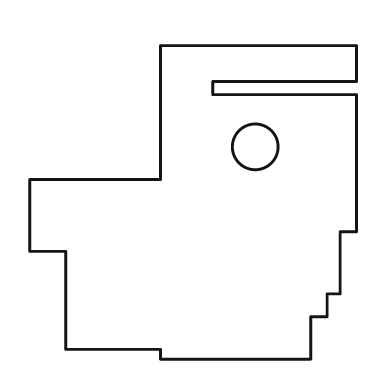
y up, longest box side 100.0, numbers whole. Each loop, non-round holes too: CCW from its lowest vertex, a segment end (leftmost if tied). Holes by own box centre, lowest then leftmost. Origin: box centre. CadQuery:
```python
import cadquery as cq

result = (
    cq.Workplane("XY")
    .moveTo(-10.0, -48.0)
    .lineTo(36.0, -48.0)
    .lineTo(36.0, -35.0)
    .lineTo(41.0, -35.0)
    .lineTo(41.0, -28.0)
    .lineTo(45.0, -28.0)
    .lineTo(45.0, -9.0)
    .lineTo(50.0, -9.0)
    .lineTo(50.0, 33.0)
    .lineTo(6.0, 33.0)
    .lineTo(6.0, 37.0)
    .lineTo(50.0, 37.0)
    .lineTo(50.0, 48.0)
    .lineTo(-10.0, 48.0)
    .lineTo(-10.0, 7.0)
    .lineTo(-50.0, 7.0)
    .lineTo(-50.0, -15.0)
    .lineTo(-39.0, -15.0)
    .lineTo(-39.0, -45.0)
    .lineTo(-10.0, -45.0)
    .close()
    .moveTo(19.0, 17.0)
    .circle(7.0)
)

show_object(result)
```